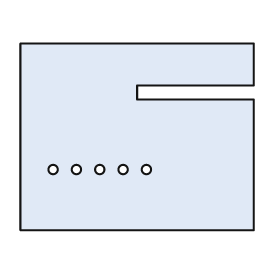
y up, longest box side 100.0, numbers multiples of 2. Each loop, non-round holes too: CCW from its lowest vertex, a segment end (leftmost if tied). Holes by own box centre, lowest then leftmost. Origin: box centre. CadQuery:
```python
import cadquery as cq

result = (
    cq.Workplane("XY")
    .moveTo(-50.0, -40.0)
    .lineTo(50.0, -40.0)
    .lineTo(50.0, 16.0)
    .lineTo(0.0, 16.0)
    .lineTo(0.0, 22.0)
    .lineTo(50.0, 22.0)
    .lineTo(50.0, 40.0)
    .lineTo(-50.0, 40.0)
    .close()
    .moveTo(-36.0, -14.0)
    .circle(2.0)
    .moveTo(-26.0, -14.0)
    .circle(2.0)
    .moveTo(-16.0, -14.0)
    .circle(2.0)
    .moveTo(-6.0, -14.0)
    .circle(2.0)
    .moveTo(4.0, -14.0)
    .circle(2.0)
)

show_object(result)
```